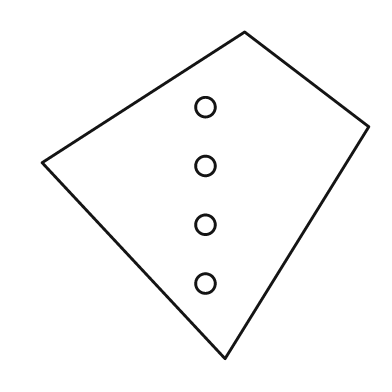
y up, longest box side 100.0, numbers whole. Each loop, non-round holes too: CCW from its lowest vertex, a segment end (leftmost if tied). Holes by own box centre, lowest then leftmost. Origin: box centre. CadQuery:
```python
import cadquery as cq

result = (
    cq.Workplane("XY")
    .moveTo(6.0, -50.0)
    .lineTo(50.0, 21.0)
    .lineTo(12.0, 50.0)
    .lineTo(-50.0, 10.0)
    .close()
    .moveTo(0.0, -27.0)
    .circle(3.0)
    .moveTo(0.0, -9.0)
    .circle(3.0)
    .moveTo(0.0, 9.0)
    .circle(3.0)
    .moveTo(0.0, 27.0)
    .circle(3.0)
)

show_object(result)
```